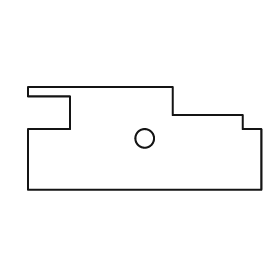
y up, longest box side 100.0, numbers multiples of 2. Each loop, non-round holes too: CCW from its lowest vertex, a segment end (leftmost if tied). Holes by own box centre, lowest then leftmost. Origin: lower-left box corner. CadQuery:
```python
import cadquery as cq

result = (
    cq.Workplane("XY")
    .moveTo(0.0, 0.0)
    .lineTo(100.0, 0.0)
    .lineTo(100.0, 26.0)
    .lineTo(92.0, 26.0)
    .lineTo(92.0, 32.0)
    .lineTo(62.0, 32.0)
    .lineTo(62.0, 44.0)
    .lineTo(0.0, 44.0)
    .lineTo(0.0, 40.0)
    .lineTo(18.0, 40.0)
    .lineTo(18.0, 26.0)
    .lineTo(0.0, 26.0)
    .close()
    .moveTo(50.0, 22.0)
    .circle(4.0)
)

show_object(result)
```